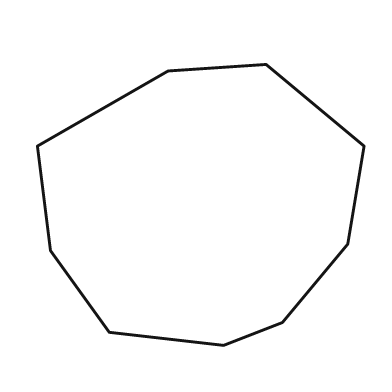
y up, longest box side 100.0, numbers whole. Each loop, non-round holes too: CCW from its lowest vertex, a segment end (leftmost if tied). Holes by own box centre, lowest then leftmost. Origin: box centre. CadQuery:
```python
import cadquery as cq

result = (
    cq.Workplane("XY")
    .moveTo(7.0, -43.0)
    .lineTo(25.0, -36.0)
    .lineTo(45.0, -12.0)
    .lineTo(50.0, 18.0)
    .lineTo(20.0, 43.0)
    .lineTo(-10.0, 41.0)
    .lineTo(-50.0, 18.0)
    .lineTo(-46.0, -14.0)
    .lineTo(-28.0, -39.0)
    .close()
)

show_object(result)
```